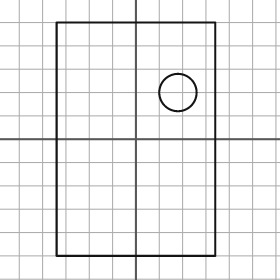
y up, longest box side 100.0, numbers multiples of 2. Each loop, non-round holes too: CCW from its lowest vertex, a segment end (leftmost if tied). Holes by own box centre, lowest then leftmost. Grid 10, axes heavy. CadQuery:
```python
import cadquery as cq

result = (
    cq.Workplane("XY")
    .moveTo(-34.0, -50.0)
    .lineTo(34.0, -50.0)
    .lineTo(34.0, 50.0)
    .lineTo(-34.0, 50.0)
    .close()
    .moveTo(18.0, 20.0)
    .circle(8.0)
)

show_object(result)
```